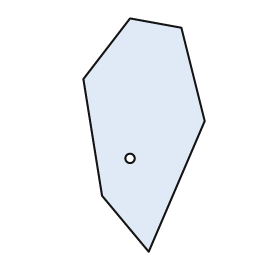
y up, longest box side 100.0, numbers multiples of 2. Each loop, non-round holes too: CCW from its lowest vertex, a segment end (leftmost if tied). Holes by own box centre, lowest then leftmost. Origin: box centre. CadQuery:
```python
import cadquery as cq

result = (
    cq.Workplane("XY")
    .moveTo(2.0, -50.0)
    .lineTo(26.0, 6.0)
    .lineTo(16.0, 46.0)
    .lineTo(-6.0, 50.0)
    .lineTo(-26.0, 24.0)
    .lineTo(-18.0, -26.0)
    .close()
    .moveTo(-6.0, -10.0)
    .circle(2.0)
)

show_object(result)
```